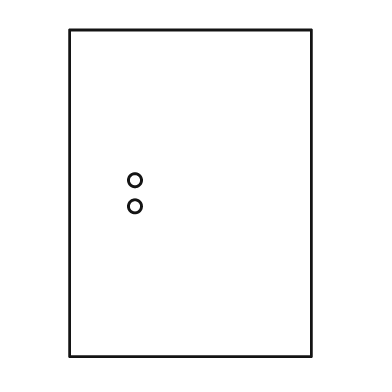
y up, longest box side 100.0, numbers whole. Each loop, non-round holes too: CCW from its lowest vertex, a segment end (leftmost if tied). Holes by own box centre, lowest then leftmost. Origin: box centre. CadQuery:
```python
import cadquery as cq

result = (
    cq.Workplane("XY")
    .moveTo(-37.0, -50.0)
    .lineTo(37.0, -50.0)
    .lineTo(37.0, 50.0)
    .lineTo(-37.0, 50.0)
    .close()
    .moveTo(-17.0, -4.0)
    .circle(2.0)
    .moveTo(-17.0, 4.0)
    .circle(2.0)
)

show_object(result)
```